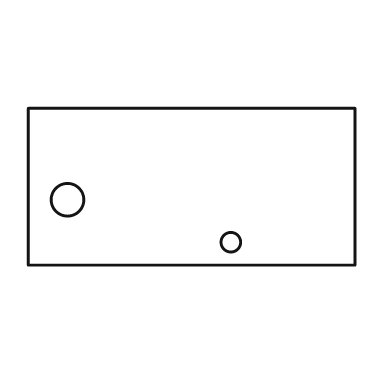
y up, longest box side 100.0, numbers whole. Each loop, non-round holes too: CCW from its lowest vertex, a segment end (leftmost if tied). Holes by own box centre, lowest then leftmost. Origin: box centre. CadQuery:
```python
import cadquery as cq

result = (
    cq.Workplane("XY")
    .moveTo(-50.0, -24.0)
    .lineTo(50.0, -24.0)
    .lineTo(50.0, 24.0)
    .lineTo(-50.0, 24.0)
    .close()
    .moveTo(12.0, -17.0)
    .circle(3.0)
    .moveTo(-38.0, -4.0)
    .circle(5.0)
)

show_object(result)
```